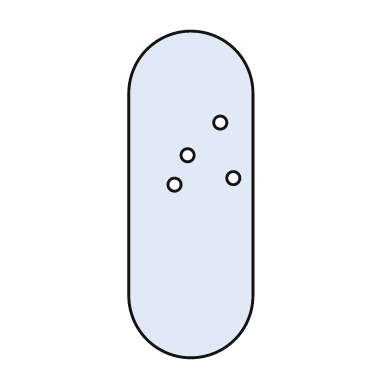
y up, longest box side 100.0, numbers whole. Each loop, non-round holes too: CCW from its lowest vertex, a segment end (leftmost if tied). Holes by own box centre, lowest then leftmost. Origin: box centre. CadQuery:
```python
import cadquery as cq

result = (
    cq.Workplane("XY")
    .moveTo(-19.0, -31.0)
    .threePointArc((0.0, -50.0), (19.0, -31.0))
    .lineTo(19.0, 31.0)
    .threePointArc((0.0, 50.0), (-19.0, 31.0))
    .close()
    .moveTo(-5.0, 3.0)
    .circle(2.0)
    .moveTo(13.0, 5.0)
    .circle(2.0)
    .moveTo(-1.0, 12.0)
    .circle(2.0)
    .moveTo(9.0, 22.0)
    .circle(2.0)
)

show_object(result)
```